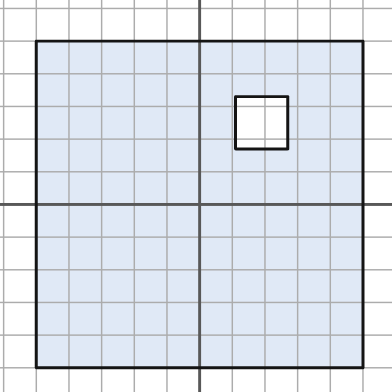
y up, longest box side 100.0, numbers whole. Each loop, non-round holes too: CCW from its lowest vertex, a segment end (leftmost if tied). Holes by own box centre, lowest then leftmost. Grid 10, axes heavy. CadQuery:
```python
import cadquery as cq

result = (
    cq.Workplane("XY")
    .moveTo(-50.0, -50.0)
    .lineTo(50.0, -50.0)
    .lineTo(50.0, 50.0)
    .lineTo(-50.0, 50.0)
    .close()
    .moveTo(11.0, 17.0)
    .lineTo(27.0, 17.0)
    .lineTo(27.0, 33.0)
    .lineTo(11.0, 33.0)
    .close()
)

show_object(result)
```